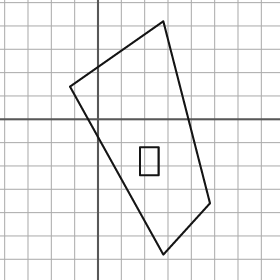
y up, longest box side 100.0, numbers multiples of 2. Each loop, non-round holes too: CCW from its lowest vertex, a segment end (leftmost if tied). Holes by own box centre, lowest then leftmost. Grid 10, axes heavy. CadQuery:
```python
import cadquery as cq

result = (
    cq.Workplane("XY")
    .moveTo(28.0, -58.0)
    .lineTo(48.0, -36.0)
    .lineTo(28.0, 42.0)
    .lineTo(-12.0, 14.0)
    .close()
    .moveTo(18.0, -24.0)
    .lineTo(26.0, -24.0)
    .lineTo(26.0, -12.0)
    .lineTo(18.0, -12.0)
    .close()
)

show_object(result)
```